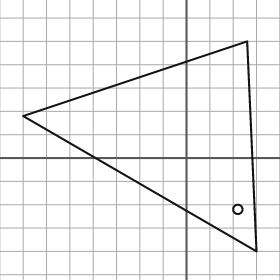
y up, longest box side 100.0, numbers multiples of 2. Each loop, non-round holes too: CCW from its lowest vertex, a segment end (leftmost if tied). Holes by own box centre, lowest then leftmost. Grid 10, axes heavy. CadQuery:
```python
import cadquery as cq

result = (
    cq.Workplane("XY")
    .moveTo(30.0, -40.0)
    .lineTo(26.0, 50.0)
    .lineTo(-70.0, 18.0)
    .close()
    .moveTo(22.0, -22.0)
    .circle(2.0)
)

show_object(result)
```